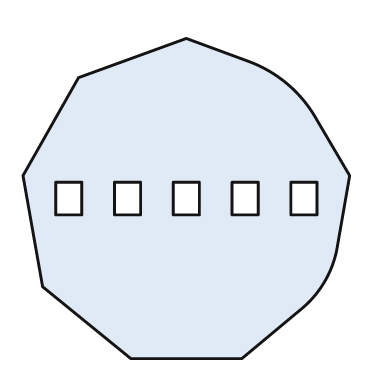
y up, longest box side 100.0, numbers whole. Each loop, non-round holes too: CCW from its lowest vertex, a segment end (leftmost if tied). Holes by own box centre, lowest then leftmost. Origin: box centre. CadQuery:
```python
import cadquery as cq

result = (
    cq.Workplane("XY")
    .moveTo(-17.0, -49.0)
    .lineTo(17.0, -49.0)
    .lineTo(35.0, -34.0)
    .threePointArc((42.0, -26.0), (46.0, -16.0))
    .lineTo(50.0, 7.0)
    .lineTo(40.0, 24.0)
    .threePointArc((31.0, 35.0), (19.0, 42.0))
    .lineTo(0.0, 49.0)
    .lineTo(-33.0, 37.0)
    .lineTo(-50.0, 7.0)
    .lineTo(-44.0, -27.0)
    .close()
    .moveTo(-40.0, -5.0)
    .lineTo(-32.0, -5.0)
    .lineTo(-32.0, 5.0)
    .lineTo(-40.0, 5.0)
    .close()
    .moveTo(-22.0, -5.0)
    .lineTo(-14.0, -5.0)
    .lineTo(-14.0, 5.0)
    .lineTo(-22.0, 5.0)
    .close()
    .moveTo(-4.0, -5.0)
    .lineTo(4.0, -5.0)
    .lineTo(4.0, 5.0)
    .lineTo(-4.0, 5.0)
    .close()
    .moveTo(14.0, -5.0)
    .lineTo(22.0, -5.0)
    .lineTo(22.0, 5.0)
    .lineTo(14.0, 5.0)
    .close()
    .moveTo(32.0, -5.0)
    .lineTo(40.0, -5.0)
    .lineTo(40.0, 5.0)
    .lineTo(32.0, 5.0)
    .close()
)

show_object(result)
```